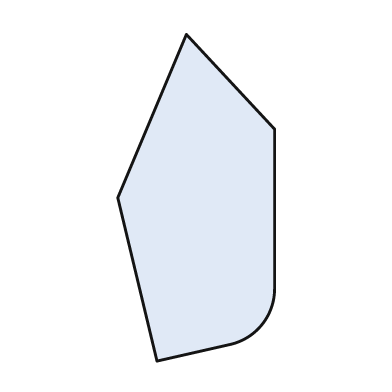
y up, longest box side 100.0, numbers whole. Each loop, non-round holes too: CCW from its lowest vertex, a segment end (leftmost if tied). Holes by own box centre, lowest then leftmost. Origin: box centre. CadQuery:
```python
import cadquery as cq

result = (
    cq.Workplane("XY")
    .moveTo(-12.0, -50.0)
    .lineTo(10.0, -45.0)
    .threePointArc((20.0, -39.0), (24.0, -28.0))
    .lineTo(24.0, 21.0)
    .lineTo(-3.0, 50.0)
    .lineTo(-24.0, 0.0)
    .close()
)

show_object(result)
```